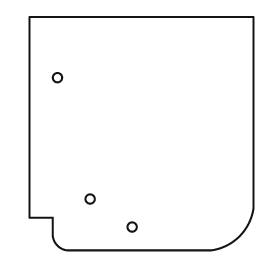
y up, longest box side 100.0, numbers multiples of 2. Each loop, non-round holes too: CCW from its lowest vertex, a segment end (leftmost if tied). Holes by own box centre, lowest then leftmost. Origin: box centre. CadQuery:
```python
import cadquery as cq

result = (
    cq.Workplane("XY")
    .moveTo(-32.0, -50.0)
    .lineTo(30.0, -50.0)
    .threePointArc((42.0, -44.0), (48.0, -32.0))
    .lineTo(48.0, 50.0)
    .lineTo(-48.0, 50.0)
    .lineTo(-48.0, -36.0)
    .lineTo(-38.0, -36.0)
    .lineTo(-38.0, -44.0)
    .threePointArc((-36.0, -48.0), (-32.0, -50.0))
    .close()
    .moveTo(-4.0, -40.0)
    .circle(2.0)
    .moveTo(-22.0, -28.0)
    .circle(2.0)
    .moveTo(-36.0, 24.0)
    .circle(2.0)
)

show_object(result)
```